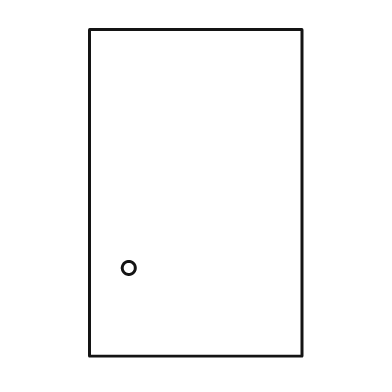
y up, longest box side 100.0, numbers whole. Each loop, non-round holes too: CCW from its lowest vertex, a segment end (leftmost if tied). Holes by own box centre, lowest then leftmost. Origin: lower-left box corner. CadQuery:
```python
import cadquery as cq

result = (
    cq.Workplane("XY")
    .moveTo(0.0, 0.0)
    .lineTo(65.0, 0.0)
    .lineTo(65.0, 100.0)
    .lineTo(0.0, 100.0)
    .close()
    .moveTo(12.0, 27.0)
    .circle(2.0)
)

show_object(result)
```